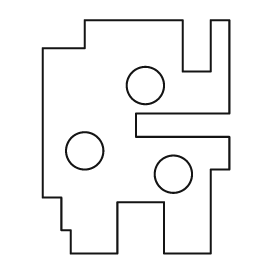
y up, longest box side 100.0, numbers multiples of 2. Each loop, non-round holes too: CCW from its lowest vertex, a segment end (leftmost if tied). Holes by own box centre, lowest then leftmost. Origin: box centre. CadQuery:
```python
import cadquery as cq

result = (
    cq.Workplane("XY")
    .moveTo(-28.0, -50.0)
    .lineTo(-8.0, -50.0)
    .lineTo(-8.0, -28.0)
    .lineTo(12.0, -28.0)
    .lineTo(12.0, -50.0)
    .lineTo(32.0, -50.0)
    .lineTo(32.0, -14.0)
    .lineTo(40.0, -14.0)
    .lineTo(40.0, 0.0)
    .lineTo(0.0, 0.0)
    .lineTo(0.0, 10.0)
    .lineTo(40.0, 10.0)
    .lineTo(40.0, 50.0)
    .lineTo(32.0, 50.0)
    .lineTo(32.0, 28.0)
    .lineTo(20.0, 28.0)
    .lineTo(20.0, 50.0)
    .lineTo(-22.0, 50.0)
    .lineTo(-22.0, 38.0)
    .lineTo(-40.0, 38.0)
    .lineTo(-40.0, -26.0)
    .lineTo(-32.0, -26.0)
    .lineTo(-32.0, -40.0)
    .lineTo(-28.0, -40.0)
    .close()
    .moveTo(16.0, -16.0)
    .circle(8.0)
    .moveTo(-22.0, -6.0)
    .circle(8.0)
    .moveTo(4.0, 22.0)
    .circle(8.0)
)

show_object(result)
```